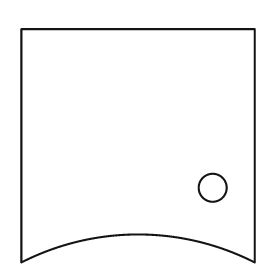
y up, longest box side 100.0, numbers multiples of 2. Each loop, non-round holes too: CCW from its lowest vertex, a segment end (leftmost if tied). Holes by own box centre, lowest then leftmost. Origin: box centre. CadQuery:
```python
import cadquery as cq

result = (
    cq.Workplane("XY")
    .moveTo(-50.0, -50.0)
    .threePointArc((0.0, -38.0), (50.0, -50.0))
    .lineTo(50.0, 50.0)
    .lineTo(-50.0, 50.0)
    .close()
    .moveTo(32.0, -18.0)
    .circle(6.0)
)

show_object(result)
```